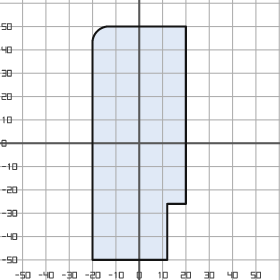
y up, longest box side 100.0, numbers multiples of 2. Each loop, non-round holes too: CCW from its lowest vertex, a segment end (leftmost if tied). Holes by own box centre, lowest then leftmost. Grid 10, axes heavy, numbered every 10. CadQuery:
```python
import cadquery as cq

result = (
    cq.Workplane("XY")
    .moveTo(-20.0, -50.0)
    .lineTo(12.0, -50.0)
    .lineTo(12.0, -26.0)
    .lineTo(20.0, -26.0)
    .lineTo(20.0, 50.0)
    .lineTo(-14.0, 50.0)
    .threePointArc((-18.0, 48.0), (-20.0, 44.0))
    .close()
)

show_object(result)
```